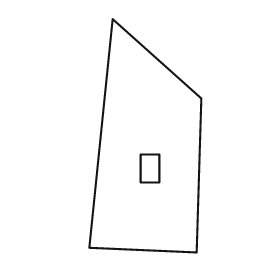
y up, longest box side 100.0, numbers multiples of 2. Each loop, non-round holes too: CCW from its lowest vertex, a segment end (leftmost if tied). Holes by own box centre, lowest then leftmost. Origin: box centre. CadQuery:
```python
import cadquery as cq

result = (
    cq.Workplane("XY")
    .moveTo(22.0, -50.0)
    .lineTo(24.0, 16.0)
    .lineTo(-14.0, 50.0)
    .lineTo(-24.0, -48.0)
    .close()
    .moveTo(-2.0, -20.0)
    .lineTo(6.0, -20.0)
    .lineTo(6.0, -8.0)
    .lineTo(-2.0, -8.0)
    .close()
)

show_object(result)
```